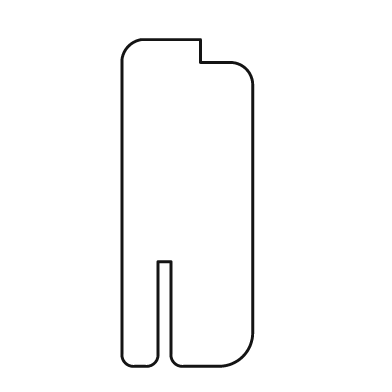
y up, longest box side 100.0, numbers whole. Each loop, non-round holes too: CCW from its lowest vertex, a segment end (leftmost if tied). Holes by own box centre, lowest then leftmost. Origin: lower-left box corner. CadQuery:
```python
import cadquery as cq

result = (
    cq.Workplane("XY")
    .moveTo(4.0, 0.0)
    .lineTo(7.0, 0.0)
    .threePointArc((10.0, 1.0), (11.0, 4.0))
    .lineTo(11.0, 32.0)
    .lineTo(15.0, 32.0)
    .lineTo(15.0, 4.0)
    .threePointArc((16.0, 1.0), (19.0, 0.0))
    .lineTo(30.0, 0.0)
    .threePointArc((37.0, 3.0), (40.0, 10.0))
    .lineTo(40.0, 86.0)
    .threePointArc((38.0, 91.0), (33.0, 93.0))
    .lineTo(24.0, 93.0)
    .lineTo(24.0, 100.0)
    .lineTo(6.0, 100.0)
    .threePointArc((2.0, 98.0), (0.0, 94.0))
    .lineTo(0.0, 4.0)
    .threePointArc((1.0, 1.0), (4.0, 0.0))
    .close()
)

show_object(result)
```